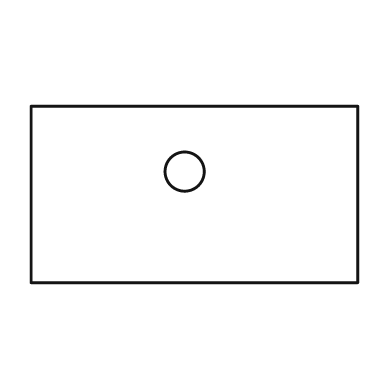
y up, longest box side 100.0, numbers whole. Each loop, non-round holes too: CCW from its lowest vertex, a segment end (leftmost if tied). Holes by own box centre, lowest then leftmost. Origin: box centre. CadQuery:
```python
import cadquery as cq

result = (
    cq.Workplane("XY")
    .moveTo(-50.0, -27.0)
    .lineTo(50.0, -27.0)
    .lineTo(50.0, 27.0)
    .lineTo(-50.0, 27.0)
    .close()
    .moveTo(-3.0, 7.0)
    .circle(6.0)
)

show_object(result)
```